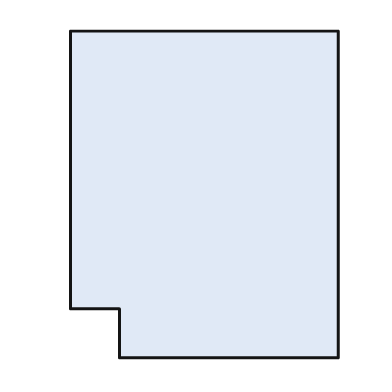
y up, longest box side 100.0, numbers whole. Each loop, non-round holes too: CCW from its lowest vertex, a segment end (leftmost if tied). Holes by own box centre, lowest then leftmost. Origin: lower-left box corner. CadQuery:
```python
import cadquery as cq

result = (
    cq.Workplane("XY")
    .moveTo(15.0, 0.0)
    .lineTo(82.0, 0.0)
    .lineTo(82.0, 100.0)
    .lineTo(0.0, 100.0)
    .lineTo(0.0, 15.0)
    .lineTo(15.0, 15.0)
    .close()
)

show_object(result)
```